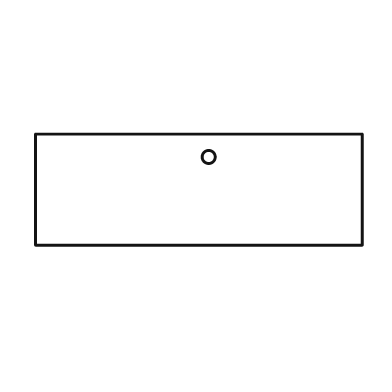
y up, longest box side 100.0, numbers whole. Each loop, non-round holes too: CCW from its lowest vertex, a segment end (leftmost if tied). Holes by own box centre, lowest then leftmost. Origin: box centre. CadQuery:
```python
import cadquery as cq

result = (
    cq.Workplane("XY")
    .moveTo(-50.0, -17.0)
    .lineTo(50.0, -17.0)
    .lineTo(50.0, 17.0)
    .lineTo(-50.0, 17.0)
    .close()
    .moveTo(3.0, 10.0)
    .circle(2.0)
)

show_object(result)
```